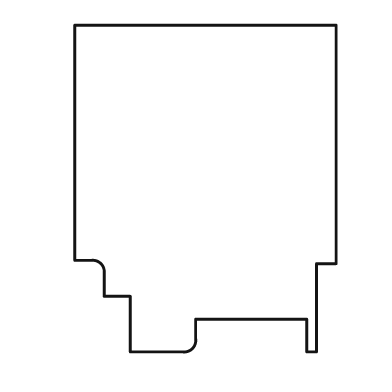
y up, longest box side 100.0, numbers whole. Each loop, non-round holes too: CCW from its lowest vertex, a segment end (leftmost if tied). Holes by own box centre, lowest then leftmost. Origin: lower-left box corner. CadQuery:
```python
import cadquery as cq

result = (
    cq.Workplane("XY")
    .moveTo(17.0, 0.0)
    .lineTo(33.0, 0.0)
    .threePointArc((36.0, 1.0), (37.0, 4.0))
    .lineTo(37.0, 10.0)
    .lineTo(71.0, 10.0)
    .lineTo(71.0, 0.0)
    .lineTo(74.0, 0.0)
    .lineTo(74.0, 27.0)
    .lineTo(80.0, 27.0)
    .lineTo(80.0, 100.0)
    .lineTo(0.0, 100.0)
    .lineTo(0.0, 28.0)
    .lineTo(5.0, 28.0)
    .threePointArc((8.0, 27.0), (9.0, 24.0))
    .lineTo(9.0, 17.0)
    .lineTo(17.0, 17.0)
    .close()
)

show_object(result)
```